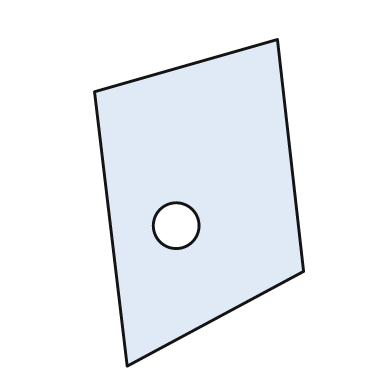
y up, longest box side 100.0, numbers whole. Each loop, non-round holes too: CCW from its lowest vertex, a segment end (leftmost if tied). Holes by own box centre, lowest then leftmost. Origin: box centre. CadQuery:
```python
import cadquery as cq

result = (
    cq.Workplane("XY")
    .moveTo(-22.0, -50.0)
    .lineTo(32.0, -21.0)
    .lineTo(24.0, 50.0)
    .lineTo(-32.0, 34.0)
    .close()
    .moveTo(-7.0, -7.0)
    .circle(7.0)
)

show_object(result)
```